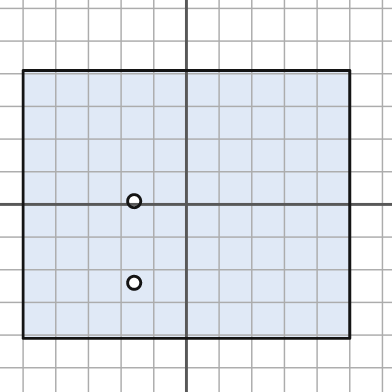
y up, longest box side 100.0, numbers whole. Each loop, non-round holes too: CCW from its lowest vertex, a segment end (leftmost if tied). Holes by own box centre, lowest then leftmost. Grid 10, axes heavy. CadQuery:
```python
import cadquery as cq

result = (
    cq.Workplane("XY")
    .moveTo(-50.0, -41.0)
    .lineTo(50.0, -41.0)
    .lineTo(50.0, 41.0)
    .lineTo(-50.0, 41.0)
    .close()
    .moveTo(-16.0, -24.0)
    .circle(2.0)
    .moveTo(-16.0, 1.0)
    .circle(2.0)
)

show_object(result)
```